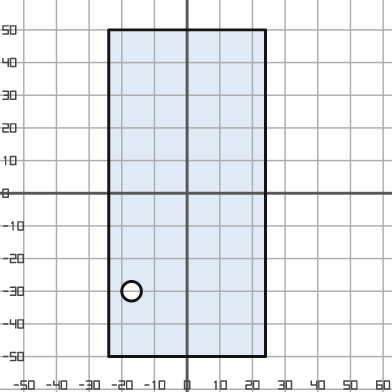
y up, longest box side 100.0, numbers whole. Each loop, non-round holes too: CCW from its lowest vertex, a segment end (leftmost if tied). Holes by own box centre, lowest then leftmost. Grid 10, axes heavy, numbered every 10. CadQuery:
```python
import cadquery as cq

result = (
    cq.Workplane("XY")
    .moveTo(-24.0, -50.0)
    .lineTo(24.0, -50.0)
    .lineTo(24.0, 50.0)
    .lineTo(-24.0, 50.0)
    .close()
    .moveTo(-17.0, -30.0)
    .circle(3.0)
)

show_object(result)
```